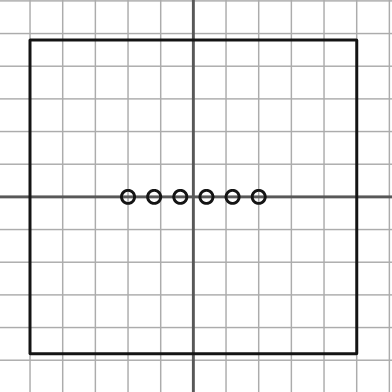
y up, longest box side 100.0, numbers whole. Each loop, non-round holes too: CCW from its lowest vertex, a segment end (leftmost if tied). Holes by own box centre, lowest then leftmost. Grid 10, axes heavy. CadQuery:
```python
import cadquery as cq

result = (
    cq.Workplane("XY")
    .moveTo(-50.0, -48.0)
    .lineTo(50.0, -48.0)
    .lineTo(50.0, 48.0)
    .lineTo(-50.0, 48.0)
    .close()
    .moveTo(-20.0, 0.0)
    .circle(2.0)
    .moveTo(-12.0, 0.0)
    .circle(2.0)
    .moveTo(-4.0, 0.0)
    .circle(2.0)
    .moveTo(4.0, 0.0)
    .circle(2.0)
    .moveTo(12.0, 0.0)
    .circle(2.0)
    .moveTo(20.0, 0.0)
    .circle(2.0)
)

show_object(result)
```